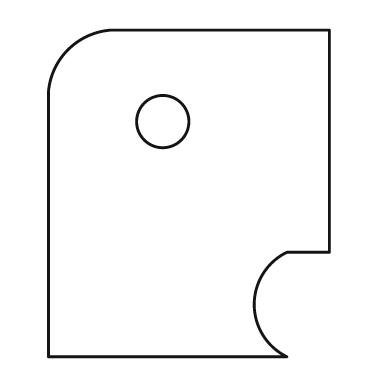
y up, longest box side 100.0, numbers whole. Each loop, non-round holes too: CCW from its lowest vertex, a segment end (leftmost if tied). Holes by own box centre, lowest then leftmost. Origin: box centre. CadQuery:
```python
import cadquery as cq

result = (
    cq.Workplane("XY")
    .moveTo(-43.0, -50.0)
    .lineTo(30.0, -50.0)
    .threePointArc((20.0, -34.0), (30.0, -18.0))
    .lineTo(43.0, -18.0)
    .lineTo(43.0, 50.0)
    .lineTo(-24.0, 50.0)
    .threePointArc((-37.0, 44.0), (-43.0, 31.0))
    .close()
    .moveTo(-8.0, 22.0)
    .circle(8.0)
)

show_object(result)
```